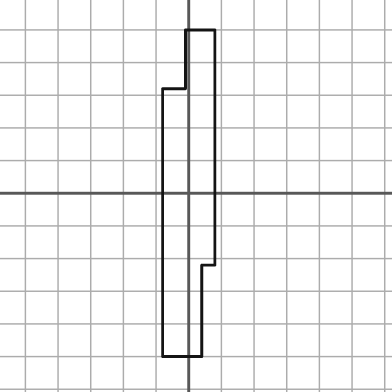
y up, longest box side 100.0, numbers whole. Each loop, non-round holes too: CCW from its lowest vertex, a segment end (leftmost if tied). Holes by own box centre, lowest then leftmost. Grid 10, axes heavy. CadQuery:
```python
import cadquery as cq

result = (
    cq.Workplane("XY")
    .moveTo(-8.0, -50.0)
    .lineTo(4.0, -50.0)
    .lineTo(4.0, -22.0)
    .lineTo(8.0, -22.0)
    .lineTo(8.0, 50.0)
    .lineTo(-1.0, 50.0)
    .lineTo(-1.0, 32.0)
    .lineTo(-8.0, 32.0)
    .close()
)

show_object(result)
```